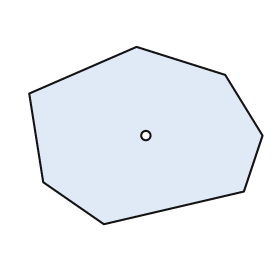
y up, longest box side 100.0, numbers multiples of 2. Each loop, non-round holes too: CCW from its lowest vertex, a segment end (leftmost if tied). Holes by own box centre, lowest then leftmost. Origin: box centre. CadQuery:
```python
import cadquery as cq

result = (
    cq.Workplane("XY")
    .moveTo(-18.0, -38.0)
    .lineTo(42.0, -24.0)
    .lineTo(50.0, 0.0)
    .lineTo(34.0, 26.0)
    .lineTo(-4.0, 38.0)
    .lineTo(-50.0, 18.0)
    .lineTo(-44.0, -20.0)
    .close()
    .moveTo(0.0, 0.0)
    .circle(2.0)
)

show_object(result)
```